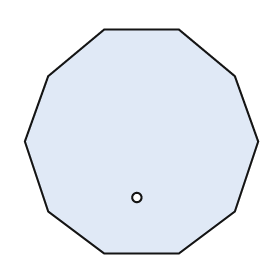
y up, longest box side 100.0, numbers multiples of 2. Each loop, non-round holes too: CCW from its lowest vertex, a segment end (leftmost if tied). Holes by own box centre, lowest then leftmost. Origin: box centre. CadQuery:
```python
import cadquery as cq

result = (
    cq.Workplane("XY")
    .moveTo(-16.0, -48.0)
    .lineTo(16.0, -48.0)
    .lineTo(40.0, -30.0)
    .lineTo(50.0, 0.0)
    .lineTo(40.0, 28.0)
    .lineTo(16.0, 48.0)
    .lineTo(-16.0, 48.0)
    .lineTo(-40.0, 28.0)
    .lineTo(-50.0, 0.0)
    .lineTo(-40.0, -30.0)
    .close()
    .moveTo(-2.0, -24.0)
    .circle(2.0)
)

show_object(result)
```